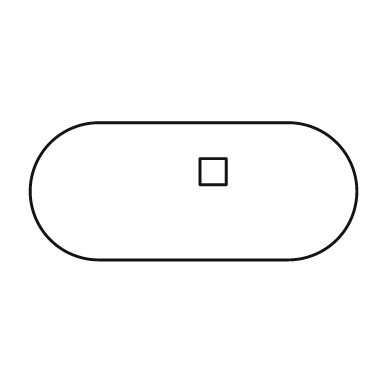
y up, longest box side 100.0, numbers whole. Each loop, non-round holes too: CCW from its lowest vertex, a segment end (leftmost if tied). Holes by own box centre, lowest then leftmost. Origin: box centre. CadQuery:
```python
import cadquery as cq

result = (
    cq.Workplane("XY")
    .moveTo(-29.0, -21.0)
    .lineTo(29.0, -21.0)
    .threePointArc((50.0, 0.0), (29.0, 21.0))
    .lineTo(-29.0, 21.0)
    .threePointArc((-50.0, 0.0), (-29.0, -21.0))
    .close()
    .moveTo(2.0, 2.0)
    .lineTo(10.0, 2.0)
    .lineTo(10.0, 10.0)
    .lineTo(2.0, 10.0)
    .close()
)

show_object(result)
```